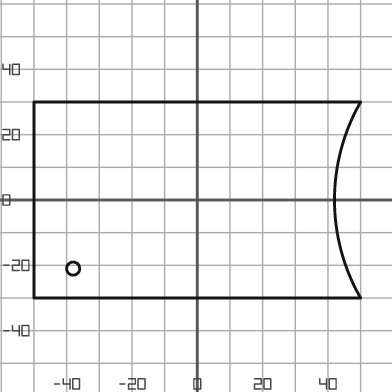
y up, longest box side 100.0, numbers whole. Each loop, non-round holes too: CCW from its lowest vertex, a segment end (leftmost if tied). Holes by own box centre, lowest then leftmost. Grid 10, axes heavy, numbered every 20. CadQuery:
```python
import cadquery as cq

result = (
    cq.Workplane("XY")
    .moveTo(-50.0, -30.0)
    .lineTo(50.0, -30.0)
    .threePointArc((42.0, 0.0), (50.0, 30.0))
    .lineTo(-50.0, 30.0)
    .close()
    .moveTo(-38.0, -21.0)
    .circle(2.0)
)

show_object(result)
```